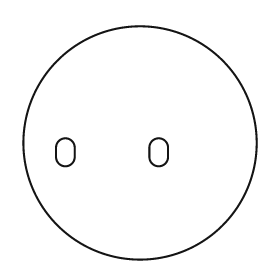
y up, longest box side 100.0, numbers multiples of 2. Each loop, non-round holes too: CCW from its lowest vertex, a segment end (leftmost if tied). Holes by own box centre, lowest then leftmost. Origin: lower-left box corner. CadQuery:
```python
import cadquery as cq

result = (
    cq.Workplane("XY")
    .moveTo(50.0, 50.0)
    .circle(50.0)
    .moveTo(14.0, 44.0)
    .threePointArc((18.0, 40.0), (22.0, 44.0))
    .lineTo(22.0, 48.0)
    .threePointArc((18.0, 52.0), (14.0, 48.0))
    .close()
    .moveTo(54.0, 44.0)
    .threePointArc((58.0, 40.0), (62.0, 44.0))
    .lineTo(62.0, 48.0)
    .threePointArc((58.0, 52.0), (54.0, 48.0))
    .close()
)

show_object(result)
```